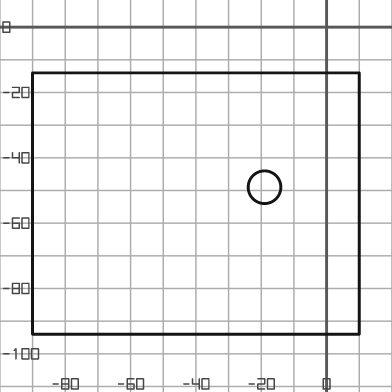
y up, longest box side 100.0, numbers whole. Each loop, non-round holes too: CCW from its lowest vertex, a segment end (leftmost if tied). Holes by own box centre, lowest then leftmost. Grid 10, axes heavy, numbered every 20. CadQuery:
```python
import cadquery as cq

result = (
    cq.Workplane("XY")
    .moveTo(-90.0, -94.0)
    .lineTo(10.0, -94.0)
    .lineTo(10.0, -14.0)
    .lineTo(-90.0, -14.0)
    .close()
    .moveTo(-19.0, -49.0)
    .circle(5.0)
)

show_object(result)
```